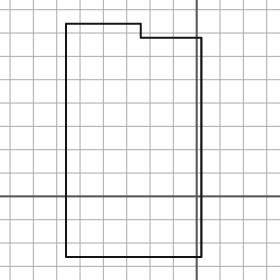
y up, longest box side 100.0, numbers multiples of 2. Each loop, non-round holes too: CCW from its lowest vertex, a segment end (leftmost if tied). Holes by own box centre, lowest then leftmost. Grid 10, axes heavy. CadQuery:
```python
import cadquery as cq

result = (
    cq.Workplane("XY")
    .moveTo(-56.0, -26.0)
    .lineTo(2.0, -26.0)
    .lineTo(2.0, 68.0)
    .lineTo(-24.0, 68.0)
    .lineTo(-24.0, 74.0)
    .lineTo(-56.0, 74.0)
    .close()
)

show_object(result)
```